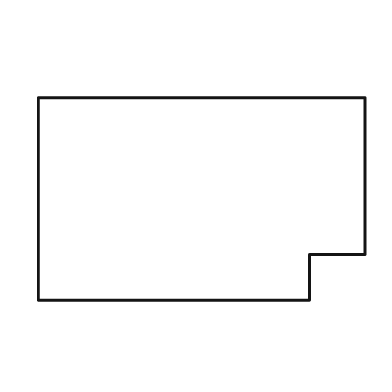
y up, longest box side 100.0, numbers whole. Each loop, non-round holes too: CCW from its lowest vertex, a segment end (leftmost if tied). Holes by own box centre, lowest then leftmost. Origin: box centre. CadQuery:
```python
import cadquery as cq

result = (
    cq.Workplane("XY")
    .moveTo(-50.0, -31.0)
    .lineTo(33.0, -31.0)
    .lineTo(33.0, -17.0)
    .lineTo(50.0, -17.0)
    .lineTo(50.0, 31.0)
    .lineTo(-50.0, 31.0)
    .close()
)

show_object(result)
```